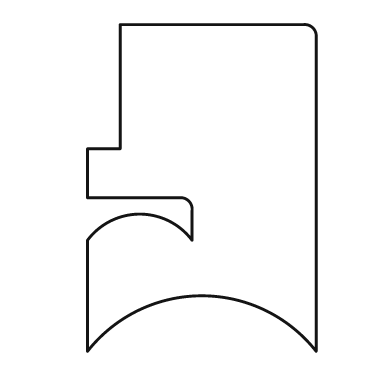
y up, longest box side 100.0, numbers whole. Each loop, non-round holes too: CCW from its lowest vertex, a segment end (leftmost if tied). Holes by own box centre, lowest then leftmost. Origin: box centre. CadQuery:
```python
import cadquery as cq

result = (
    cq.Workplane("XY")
    .moveTo(-35.0, -50.0)
    .threePointArc((0.0, -33.0), (35.0, -50.0))
    .lineTo(35.0, 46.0)
    .threePointArc((34.0, 49.0), (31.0, 50.0))
    .lineTo(-25.0, 50.0)
    .lineTo(-25.0, 12.0)
    .lineTo(-35.0, 12.0)
    .lineTo(-35.0, -3.0)
    .lineTo(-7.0, -3.0)
    .threePointArc((-4.0, -4.0), (-3.0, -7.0))
    .lineTo(-3.0, -16.0)
    .threePointArc((-19.0, -8.0), (-35.0, -16.0))
    .close()
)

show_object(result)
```